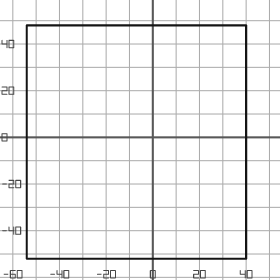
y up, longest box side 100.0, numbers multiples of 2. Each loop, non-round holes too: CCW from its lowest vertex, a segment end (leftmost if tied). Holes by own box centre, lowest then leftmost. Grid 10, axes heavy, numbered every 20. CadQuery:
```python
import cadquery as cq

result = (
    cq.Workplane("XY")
    .moveTo(-54.0, -52.0)
    .lineTo(40.0, -52.0)
    .lineTo(40.0, 48.0)
    .lineTo(-54.0, 48.0)
    .close()
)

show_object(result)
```